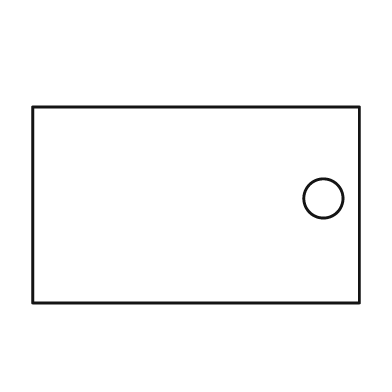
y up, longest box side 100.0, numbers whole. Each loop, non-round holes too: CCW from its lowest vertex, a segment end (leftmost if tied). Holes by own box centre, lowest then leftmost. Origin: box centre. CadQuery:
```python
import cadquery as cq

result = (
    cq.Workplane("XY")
    .moveTo(-50.0, -30.0)
    .lineTo(50.0, -30.0)
    .lineTo(50.0, 30.0)
    .lineTo(-50.0, 30.0)
    .close()
    .moveTo(39.0, 2.0)
    .circle(6.0)
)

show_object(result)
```